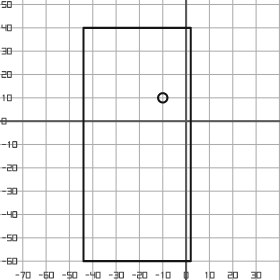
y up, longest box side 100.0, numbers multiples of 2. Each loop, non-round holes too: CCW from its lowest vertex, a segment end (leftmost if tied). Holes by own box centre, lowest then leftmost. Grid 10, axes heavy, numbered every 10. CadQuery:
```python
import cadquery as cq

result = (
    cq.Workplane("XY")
    .moveTo(-44.0, -60.0)
    .lineTo(2.0, -60.0)
    .lineTo(2.0, 40.0)
    .lineTo(-44.0, 40.0)
    .close()
    .moveTo(-10.0, 10.0)
    .circle(2.0)
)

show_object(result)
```